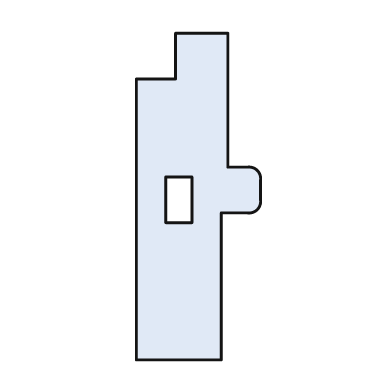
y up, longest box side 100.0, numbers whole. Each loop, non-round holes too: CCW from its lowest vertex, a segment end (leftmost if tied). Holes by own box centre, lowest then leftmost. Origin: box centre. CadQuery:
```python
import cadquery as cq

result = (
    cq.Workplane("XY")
    .moveTo(-19.0, -50.0)
    .lineTo(7.0, -50.0)
    .lineTo(7.0, -5.0)
    .lineTo(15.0, -5.0)
    .threePointArc((18.0, -4.0), (19.0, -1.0))
    .lineTo(19.0, 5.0)
    .threePointArc((18.0, 8.0), (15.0, 9.0))
    .lineTo(9.0, 9.0)
    .lineTo(9.0, 50.0)
    .lineTo(-7.0, 50.0)
    .lineTo(-7.0, 36.0)
    .lineTo(-19.0, 36.0)
    .close()
    .moveTo(-10.0, -8.0)
    .lineTo(-2.0, -8.0)
    .lineTo(-2.0, 6.0)
    .lineTo(-10.0, 6.0)
    .close()
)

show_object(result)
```